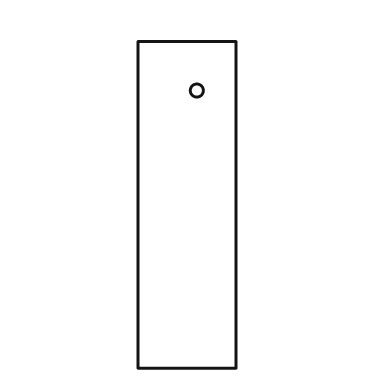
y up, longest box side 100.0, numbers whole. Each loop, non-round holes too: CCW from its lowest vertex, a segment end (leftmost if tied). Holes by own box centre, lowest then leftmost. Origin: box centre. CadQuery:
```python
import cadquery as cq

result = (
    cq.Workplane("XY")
    .moveTo(-15.0, -50.0)
    .lineTo(15.0, -50.0)
    .lineTo(15.0, 50.0)
    .lineTo(-15.0, 50.0)
    .close()
    .moveTo(3.0, 35.0)
    .circle(2.0)
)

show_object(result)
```